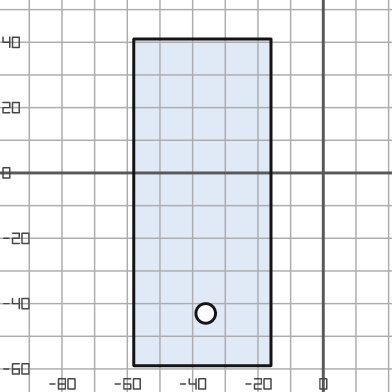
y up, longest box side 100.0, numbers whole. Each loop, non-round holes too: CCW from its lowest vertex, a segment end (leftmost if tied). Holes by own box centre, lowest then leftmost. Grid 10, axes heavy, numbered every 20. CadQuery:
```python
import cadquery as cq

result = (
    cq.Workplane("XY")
    .moveTo(-58.0, -59.0)
    .lineTo(-16.0, -59.0)
    .lineTo(-16.0, 41.0)
    .lineTo(-58.0, 41.0)
    .close()
    .moveTo(-36.0, -43.0)
    .circle(3.0)
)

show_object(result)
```